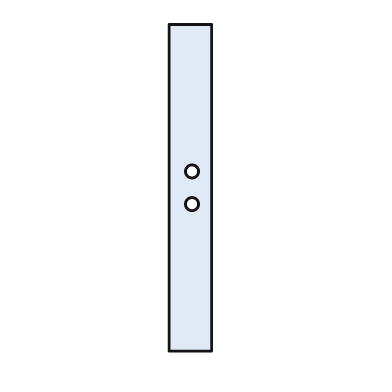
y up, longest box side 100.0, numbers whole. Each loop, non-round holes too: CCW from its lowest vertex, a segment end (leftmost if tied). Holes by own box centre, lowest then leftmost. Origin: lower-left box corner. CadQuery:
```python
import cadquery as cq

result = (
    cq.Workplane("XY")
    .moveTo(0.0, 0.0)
    .lineTo(13.0, 0.0)
    .lineTo(13.0, 100.0)
    .lineTo(0.0, 100.0)
    .close()
    .moveTo(7.0, 45.0)
    .circle(2.0)
    .moveTo(7.0, 55.0)
    .circle(2.0)
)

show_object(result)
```